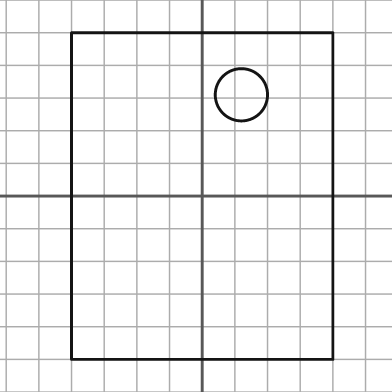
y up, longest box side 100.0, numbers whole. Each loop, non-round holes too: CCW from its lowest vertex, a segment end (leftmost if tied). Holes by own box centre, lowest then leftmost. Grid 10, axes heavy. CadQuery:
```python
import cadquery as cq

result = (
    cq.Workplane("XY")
    .moveTo(-40.0, -50.0)
    .lineTo(40.0, -50.0)
    .lineTo(40.0, 50.0)
    .lineTo(-40.0, 50.0)
    .close()
    .moveTo(12.0, 31.0)
    .circle(8.0)
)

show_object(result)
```